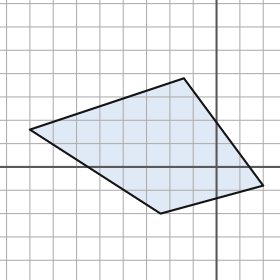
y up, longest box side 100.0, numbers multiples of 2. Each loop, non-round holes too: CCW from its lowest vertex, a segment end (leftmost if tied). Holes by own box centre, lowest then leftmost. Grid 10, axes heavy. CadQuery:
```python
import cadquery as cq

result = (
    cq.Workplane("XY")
    .moveTo(-24.0, -20.0)
    .lineTo(20.0, -8.0)
    .lineTo(-14.0, 38.0)
    .lineTo(-80.0, 16.0)
    .close()
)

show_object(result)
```